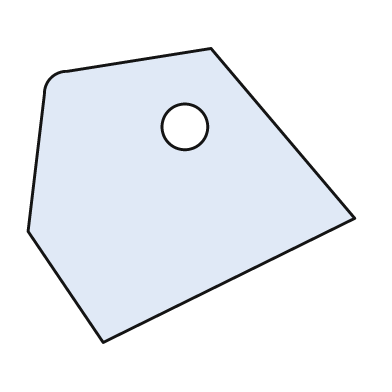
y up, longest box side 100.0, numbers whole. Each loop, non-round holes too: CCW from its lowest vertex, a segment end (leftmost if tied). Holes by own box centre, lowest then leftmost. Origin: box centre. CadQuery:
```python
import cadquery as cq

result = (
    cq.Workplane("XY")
    .moveTo(-27.0, -45.0)
    .lineTo(50.0, -7.0)
    .lineTo(6.0, 45.0)
    .lineTo(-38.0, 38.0)
    .threePointArc((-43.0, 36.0), (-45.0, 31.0))
    .lineTo(-50.0, -11.0)
    .close()
    .moveTo(-2.0, 21.0)
    .circle(7.0)
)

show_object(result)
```